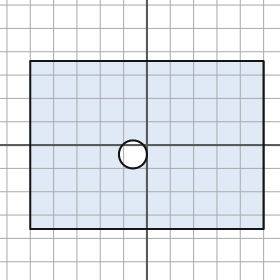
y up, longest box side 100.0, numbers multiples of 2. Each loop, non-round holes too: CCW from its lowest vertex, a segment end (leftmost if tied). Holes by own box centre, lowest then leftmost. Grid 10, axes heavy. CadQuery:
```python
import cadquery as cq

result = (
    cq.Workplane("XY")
    .moveTo(-50.0, -36.0)
    .lineTo(50.0, -36.0)
    .lineTo(50.0, 36.0)
    .lineTo(-50.0, 36.0)
    .close()
    .moveTo(-6.0, -4.0)
    .circle(6.0)
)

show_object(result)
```